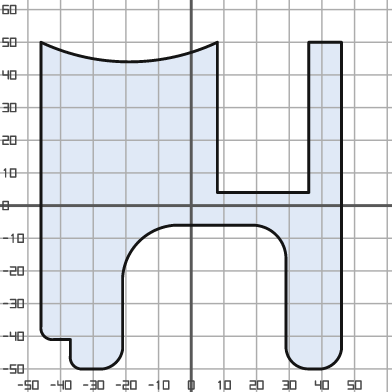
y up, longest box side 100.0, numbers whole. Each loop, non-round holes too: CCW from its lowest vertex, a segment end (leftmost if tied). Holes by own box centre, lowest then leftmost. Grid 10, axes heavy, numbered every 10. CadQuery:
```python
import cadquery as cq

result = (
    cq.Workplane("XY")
    .moveTo(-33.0, -50.0)
    .lineTo(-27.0, -50.0)
    .threePointArc((-23.0, -48.0), (-21.0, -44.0))
    .lineTo(-21.0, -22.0)
    .threePointArc((-16.0, -11.0), (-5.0, -6.0))
    .lineTo(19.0, -6.0)
    .threePointArc((26.0, -9.0), (29.0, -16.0))
    .lineTo(29.0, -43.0)
    .threePointArc((31.0, -48.0), (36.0, -50.0))
    .lineTo(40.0, -50.0)
    .threePointArc((44.0, -48.0), (46.0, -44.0))
    .lineTo(46.0, 50.0)
    .lineTo(36.0, 50.0)
    .lineTo(36.0, 4.0)
    .lineTo(8.0, 4.0)
    .lineTo(8.0, 50.0)
    .threePointArc((-19.0, 44.0), (-46.0, 50.0))
    .lineTo(-46.0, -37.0)
    .threePointArc((-45.0, -40.0), (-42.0, -41.0))
    .lineTo(-37.0, -41.0)
    .lineTo(-37.0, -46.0)
    .threePointArc((-36.0, -49.0), (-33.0, -50.0))
    .close()
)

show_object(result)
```